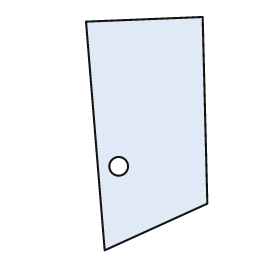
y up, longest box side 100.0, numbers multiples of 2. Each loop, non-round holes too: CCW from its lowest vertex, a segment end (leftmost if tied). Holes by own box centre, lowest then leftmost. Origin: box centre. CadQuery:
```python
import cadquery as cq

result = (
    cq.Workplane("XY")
    .moveTo(-18.0, -50.0)
    .lineTo(26.0, -30.0)
    .lineTo(24.0, 50.0)
    .lineTo(-26.0, 48.0)
    .close()
    .moveTo(-12.0, -14.0)
    .circle(4.0)
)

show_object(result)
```